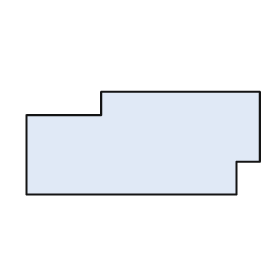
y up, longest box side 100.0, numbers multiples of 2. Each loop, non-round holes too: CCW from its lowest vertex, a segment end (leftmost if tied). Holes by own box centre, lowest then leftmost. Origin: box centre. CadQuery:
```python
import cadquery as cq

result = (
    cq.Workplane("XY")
    .moveTo(-50.0, -22.0)
    .lineTo(40.0, -22.0)
    .lineTo(40.0, -8.0)
    .lineTo(50.0, -8.0)
    .lineTo(50.0, 22.0)
    .lineTo(-18.0, 22.0)
    .lineTo(-18.0, 12.0)
    .lineTo(-50.0, 12.0)
    .close()
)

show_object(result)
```